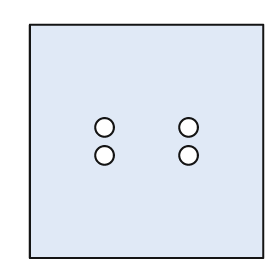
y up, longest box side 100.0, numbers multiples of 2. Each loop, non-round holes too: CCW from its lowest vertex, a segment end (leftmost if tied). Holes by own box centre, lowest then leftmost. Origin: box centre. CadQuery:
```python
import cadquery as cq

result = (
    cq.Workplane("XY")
    .moveTo(-50.0, -50.0)
    .lineTo(50.0, -50.0)
    .lineTo(50.0, 50.0)
    .lineTo(-50.0, 50.0)
    .close()
    .moveTo(-18.0, -6.0)
    .circle(4.0)
    .moveTo(18.0, -6.0)
    .circle(4.0)
    .moveTo(-18.0, 6.0)
    .circle(4.0)
    .moveTo(18.0, 6.0)
    .circle(4.0)
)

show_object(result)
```